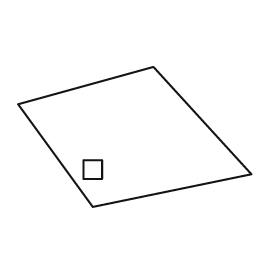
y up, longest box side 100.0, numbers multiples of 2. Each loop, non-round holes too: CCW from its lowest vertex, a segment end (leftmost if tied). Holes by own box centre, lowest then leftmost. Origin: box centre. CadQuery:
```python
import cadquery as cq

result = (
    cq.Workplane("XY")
    .moveTo(-18.0, -30.0)
    .lineTo(50.0, -16.0)
    .lineTo(8.0, 30.0)
    .lineTo(-50.0, 14.0)
    .close()
    .moveTo(-22.0, -18.0)
    .lineTo(-14.0, -18.0)
    .lineTo(-14.0, -10.0)
    .lineTo(-22.0, -10.0)
    .close()
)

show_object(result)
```